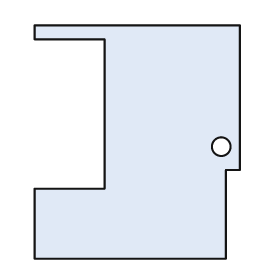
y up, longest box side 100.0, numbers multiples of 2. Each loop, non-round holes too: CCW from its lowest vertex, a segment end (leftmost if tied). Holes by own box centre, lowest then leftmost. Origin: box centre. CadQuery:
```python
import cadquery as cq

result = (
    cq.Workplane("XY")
    .moveTo(-44.0, -50.0)
    .lineTo(38.0, -50.0)
    .lineTo(38.0, -12.0)
    .lineTo(44.0, -12.0)
    .lineTo(44.0, 50.0)
    .lineTo(-44.0, 50.0)
    .lineTo(-44.0, 44.0)
    .lineTo(-14.0, 44.0)
    .lineTo(-14.0, -20.0)
    .lineTo(-44.0, -20.0)
    .close()
    .moveTo(36.0, -2.0)
    .circle(4.0)
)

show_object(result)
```